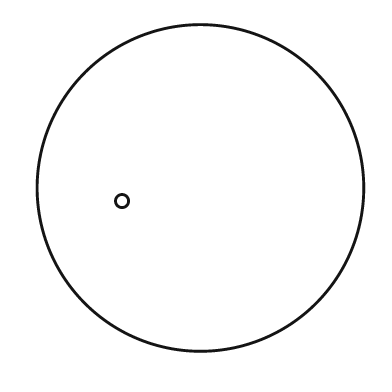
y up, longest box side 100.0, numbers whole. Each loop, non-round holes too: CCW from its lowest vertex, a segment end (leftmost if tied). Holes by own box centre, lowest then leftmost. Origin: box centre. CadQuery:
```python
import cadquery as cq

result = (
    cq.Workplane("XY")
    .moveTo(0.0, 0.0)
    .circle(50.0)
    .moveTo(-24.0, -4.0)
    .circle(2.0)
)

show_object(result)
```